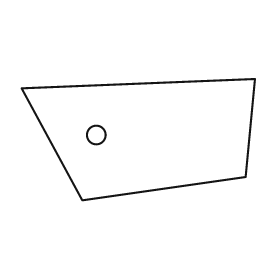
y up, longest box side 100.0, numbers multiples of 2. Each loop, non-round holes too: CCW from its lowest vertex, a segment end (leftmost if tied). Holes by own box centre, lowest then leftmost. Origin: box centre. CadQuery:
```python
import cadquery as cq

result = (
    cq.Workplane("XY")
    .moveTo(-24.0, -26.0)
    .lineTo(46.0, -16.0)
    .lineTo(50.0, 26.0)
    .lineTo(-50.0, 22.0)
    .close()
    .moveTo(-18.0, 2.0)
    .circle(4.0)
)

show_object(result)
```